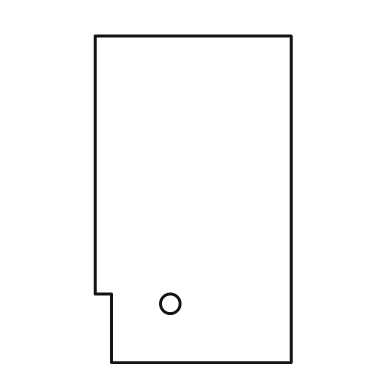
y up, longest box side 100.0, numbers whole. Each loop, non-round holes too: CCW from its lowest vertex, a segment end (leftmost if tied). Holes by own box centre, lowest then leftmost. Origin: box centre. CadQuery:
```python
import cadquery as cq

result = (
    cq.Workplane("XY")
    .moveTo(-25.0, -50.0)
    .lineTo(30.0, -50.0)
    .lineTo(30.0, 50.0)
    .lineTo(-30.0, 50.0)
    .lineTo(-30.0, -29.0)
    .lineTo(-25.0, -29.0)
    .close()
    .moveTo(-7.0, -32.0)
    .circle(3.0)
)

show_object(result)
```